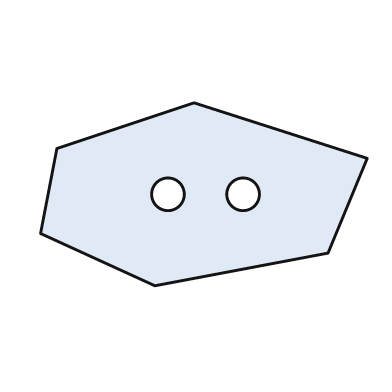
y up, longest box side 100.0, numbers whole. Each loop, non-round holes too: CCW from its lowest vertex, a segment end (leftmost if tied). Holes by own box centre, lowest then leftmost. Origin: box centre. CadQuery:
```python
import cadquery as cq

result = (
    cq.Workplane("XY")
    .moveTo(-15.0, -28.0)
    .lineTo(38.0, -18.0)
    .lineTo(50.0, 11.0)
    .lineTo(-3.0, 28.0)
    .lineTo(-45.0, 14.0)
    .lineTo(-50.0, -12.0)
    .close()
    .moveTo(-11.0, 0.0)
    .circle(5.0)
    .moveTo(12.0, 0.0)
    .circle(5.0)
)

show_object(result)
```